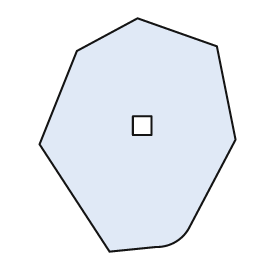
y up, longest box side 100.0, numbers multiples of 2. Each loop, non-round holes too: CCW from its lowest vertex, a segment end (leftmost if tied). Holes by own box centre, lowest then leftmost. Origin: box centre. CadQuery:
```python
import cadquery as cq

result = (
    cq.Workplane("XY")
    .moveTo(-12.0, -50.0)
    .lineTo(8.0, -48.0)
    .threePointArc((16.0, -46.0), (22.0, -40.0))
    .lineTo(42.0, -2.0)
    .lineTo(34.0, 38.0)
    .lineTo(0.0, 50.0)
    .lineTo(-26.0, 36.0)
    .lineTo(-42.0, -4.0)
    .close()
    .moveTo(-2.0, 0.0)
    .lineTo(6.0, 0.0)
    .lineTo(6.0, 8.0)
    .lineTo(-2.0, 8.0)
    .close()
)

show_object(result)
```